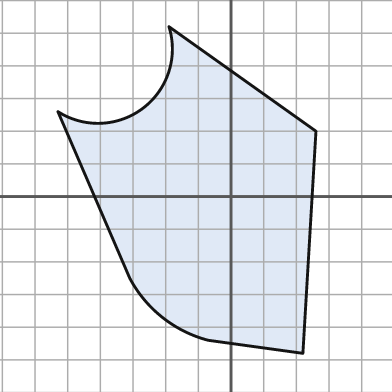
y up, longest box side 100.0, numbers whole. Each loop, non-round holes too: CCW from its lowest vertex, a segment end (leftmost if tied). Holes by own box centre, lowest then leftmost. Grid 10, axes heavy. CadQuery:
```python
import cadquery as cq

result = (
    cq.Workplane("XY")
    .moveTo(22.0, -48.0)
    .lineTo(26.0, 20.0)
    .lineTo(-19.0, 52.0)
    .threePointArc((-27.0, 27.0), (-53.0, 26.0))
    .lineTo(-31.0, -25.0)
    .threePointArc((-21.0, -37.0), (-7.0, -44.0))
    .close()
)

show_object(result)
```